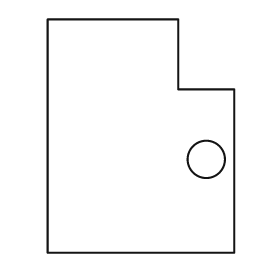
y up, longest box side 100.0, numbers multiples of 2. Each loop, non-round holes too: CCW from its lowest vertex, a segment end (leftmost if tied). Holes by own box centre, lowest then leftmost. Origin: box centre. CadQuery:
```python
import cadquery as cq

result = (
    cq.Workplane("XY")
    .moveTo(-40.0, -50.0)
    .lineTo(40.0, -50.0)
    .lineTo(40.0, 20.0)
    .lineTo(16.0, 20.0)
    .lineTo(16.0, 50.0)
    .lineTo(-40.0, 50.0)
    .close()
    .moveTo(28.0, -10.0)
    .circle(8.0)
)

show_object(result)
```